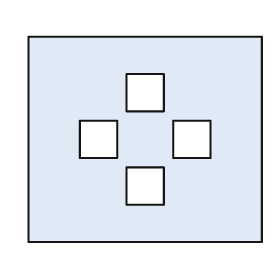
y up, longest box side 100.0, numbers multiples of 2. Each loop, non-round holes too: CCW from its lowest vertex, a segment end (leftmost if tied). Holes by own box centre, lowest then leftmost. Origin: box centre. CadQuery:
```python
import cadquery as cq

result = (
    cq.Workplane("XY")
    .moveTo(-50.0, -44.0)
    .lineTo(50.0, -44.0)
    .lineTo(50.0, 44.0)
    .lineTo(-50.0, 44.0)
    .close()
    .moveTo(-8.0, -28.0)
    .lineTo(8.0, -28.0)
    .lineTo(8.0, -12.0)
    .lineTo(-8.0, -12.0)
    .close()
    .moveTo(-28.0, -8.0)
    .lineTo(-12.0, -8.0)
    .lineTo(-12.0, 8.0)
    .lineTo(-28.0, 8.0)
    .close()
    .moveTo(12.0, -8.0)
    .lineTo(28.0, -8.0)
    .lineTo(28.0, 8.0)
    .lineTo(12.0, 8.0)
    .close()
    .moveTo(-8.0, 12.0)
    .lineTo(8.0, 12.0)
    .lineTo(8.0, 28.0)
    .lineTo(-8.0, 28.0)
    .close()
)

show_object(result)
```